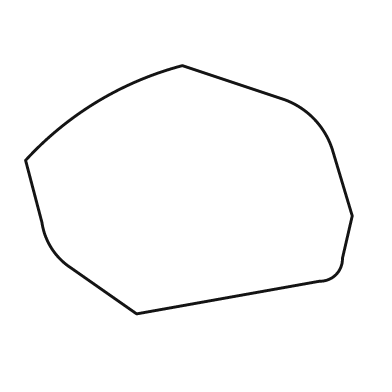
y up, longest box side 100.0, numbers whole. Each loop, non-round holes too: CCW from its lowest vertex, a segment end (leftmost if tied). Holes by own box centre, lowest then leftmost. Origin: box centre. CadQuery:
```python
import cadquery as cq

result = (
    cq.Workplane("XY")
    .moveTo(-16.0, -38.0)
    .lineTo(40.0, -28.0)
    .threePointArc((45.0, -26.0), (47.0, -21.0))
    .lineTo(50.0, -8.0)
    .lineTo(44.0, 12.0)
    .threePointArc((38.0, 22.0), (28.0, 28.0))
    .lineTo(-2.0, 38.0)
    .threePointArc((-28.0, 27.0), (-50.0, 9.0))
    .lineTo(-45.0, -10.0)
    .threePointArc((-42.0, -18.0), (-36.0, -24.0))
    .close()
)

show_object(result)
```